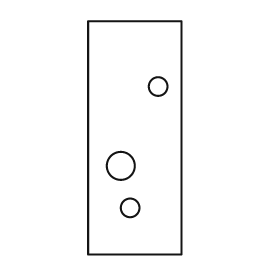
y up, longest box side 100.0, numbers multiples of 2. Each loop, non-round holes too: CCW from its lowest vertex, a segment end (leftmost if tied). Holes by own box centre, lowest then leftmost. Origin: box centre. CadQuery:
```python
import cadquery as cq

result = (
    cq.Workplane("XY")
    .moveTo(-20.0, -50.0)
    .lineTo(20.0, -50.0)
    .lineTo(20.0, 50.0)
    .lineTo(-20.0, 50.0)
    .close()
    .moveTo(-2.0, -30.0)
    .circle(4.0)
    .moveTo(-6.0, -12.0)
    .circle(6.0)
    .moveTo(10.0, 22.0)
    .circle(4.0)
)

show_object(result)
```